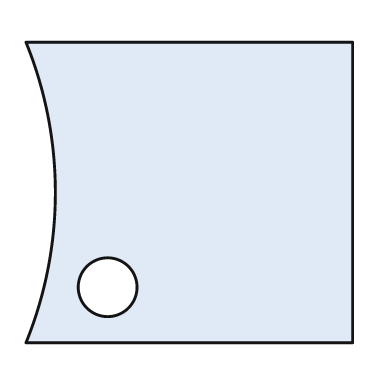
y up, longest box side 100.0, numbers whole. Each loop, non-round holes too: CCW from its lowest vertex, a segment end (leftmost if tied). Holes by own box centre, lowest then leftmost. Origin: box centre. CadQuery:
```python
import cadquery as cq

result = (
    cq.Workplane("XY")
    .moveTo(-50.0, -46.0)
    .lineTo(50.0, -46.0)
    .lineTo(50.0, 46.0)
    .lineTo(-50.0, 46.0)
    .threePointArc((-41.0, 0.0), (-50.0, -46.0))
    .close()
    .moveTo(-25.0, -29.0)
    .circle(9.0)
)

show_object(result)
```